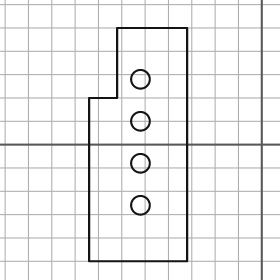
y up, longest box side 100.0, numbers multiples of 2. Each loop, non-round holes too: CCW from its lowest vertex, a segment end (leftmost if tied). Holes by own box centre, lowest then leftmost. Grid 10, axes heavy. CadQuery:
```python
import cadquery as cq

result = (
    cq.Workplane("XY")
    .moveTo(-74.0, -50.0)
    .lineTo(-32.0, -50.0)
    .lineTo(-32.0, 50.0)
    .lineTo(-62.0, 50.0)
    .lineTo(-62.0, 20.0)
    .lineTo(-74.0, 20.0)
    .close()
    .moveTo(-52.0, -26.0)
    .circle(4.0)
    .moveTo(-52.0, -8.0)
    .circle(4.0)
    .moveTo(-52.0, 10.0)
    .circle(4.0)
    .moveTo(-52.0, 28.0)
    .circle(4.0)
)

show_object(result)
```